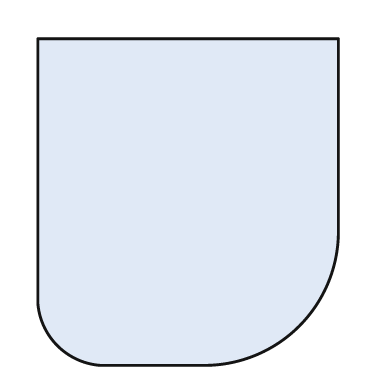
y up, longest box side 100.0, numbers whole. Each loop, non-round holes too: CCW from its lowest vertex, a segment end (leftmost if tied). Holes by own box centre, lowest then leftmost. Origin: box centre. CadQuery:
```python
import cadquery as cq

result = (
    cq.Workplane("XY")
    .moveTo(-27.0, -50.0)
    .lineTo(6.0, -50.0)
    .threePointArc((34.0, -38.0), (46.0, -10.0))
    .lineTo(46.0, 50.0)
    .lineTo(-46.0, 50.0)
    .lineTo(-46.0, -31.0)
    .threePointArc((-40.0, -44.0), (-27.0, -50.0))
    .close()
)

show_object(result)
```